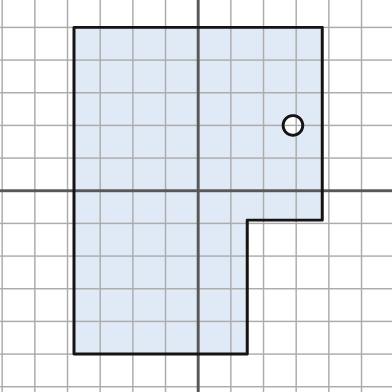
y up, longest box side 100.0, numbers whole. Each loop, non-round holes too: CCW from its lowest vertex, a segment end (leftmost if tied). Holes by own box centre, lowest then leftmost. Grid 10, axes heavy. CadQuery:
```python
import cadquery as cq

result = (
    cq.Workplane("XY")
    .moveTo(-38.0, -50.0)
    .lineTo(15.0, -50.0)
    .lineTo(15.0, -9.0)
    .lineTo(38.0, -9.0)
    .lineTo(38.0, 50.0)
    .lineTo(-38.0, 50.0)
    .close()
    .moveTo(29.0, 20.0)
    .circle(3.0)
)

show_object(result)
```